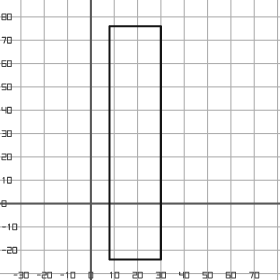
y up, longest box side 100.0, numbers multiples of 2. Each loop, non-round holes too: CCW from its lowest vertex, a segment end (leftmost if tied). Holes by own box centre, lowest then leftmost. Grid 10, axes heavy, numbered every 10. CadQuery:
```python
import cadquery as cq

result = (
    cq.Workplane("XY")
    .moveTo(8.0, -24.0)
    .lineTo(30.0, -24.0)
    .lineTo(30.0, 76.0)
    .lineTo(8.0, 76.0)
    .close()
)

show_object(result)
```